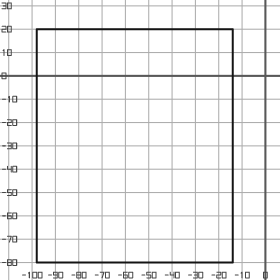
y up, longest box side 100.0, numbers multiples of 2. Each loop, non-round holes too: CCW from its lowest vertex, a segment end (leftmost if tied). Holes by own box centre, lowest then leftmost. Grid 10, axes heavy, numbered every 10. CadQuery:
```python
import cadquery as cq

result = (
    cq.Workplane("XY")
    .moveTo(-98.0, -80.0)
    .lineTo(-14.0, -80.0)
    .lineTo(-14.0, 20.0)
    .lineTo(-98.0, 20.0)
    .close()
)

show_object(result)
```